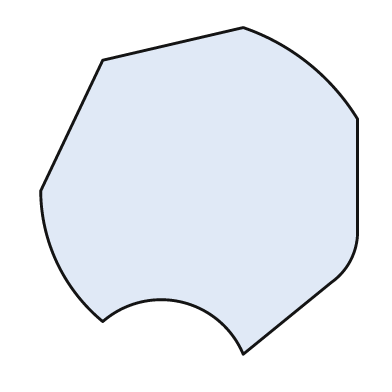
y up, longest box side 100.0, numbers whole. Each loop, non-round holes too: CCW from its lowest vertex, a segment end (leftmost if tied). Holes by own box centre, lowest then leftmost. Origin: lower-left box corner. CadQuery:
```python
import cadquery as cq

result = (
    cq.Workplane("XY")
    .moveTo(62.0, 0.0)
    .lineTo(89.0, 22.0)
    .threePointArc((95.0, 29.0), (97.0, 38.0))
    .lineTo(97.0, 72.0)
    .threePointArc((82.0, 89.0), (62.0, 100.0))
    .lineTo(19.0, 90.0)
    .lineTo(0.0, 50.0)
    .threePointArc((5.0, 28.0), (19.0, 10.0))
    .threePointArc((43.0, 16.0), (62.0, 0.0))
    .close()
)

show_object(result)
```